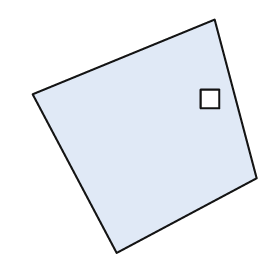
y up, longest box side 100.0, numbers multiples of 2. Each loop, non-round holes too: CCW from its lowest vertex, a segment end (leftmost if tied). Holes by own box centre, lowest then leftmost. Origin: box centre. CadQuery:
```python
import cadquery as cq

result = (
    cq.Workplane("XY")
    .moveTo(-12.0, -50.0)
    .lineTo(48.0, -18.0)
    .lineTo(30.0, 50.0)
    .lineTo(-48.0, 18.0)
    .close()
    .moveTo(24.0, 12.0)
    .lineTo(32.0, 12.0)
    .lineTo(32.0, 20.0)
    .lineTo(24.0, 20.0)
    .close()
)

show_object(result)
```